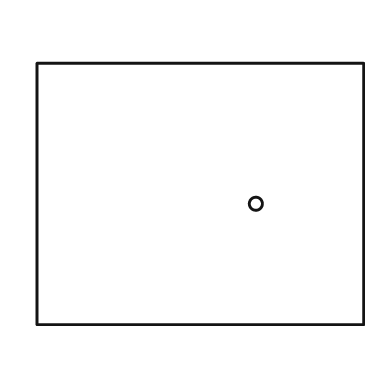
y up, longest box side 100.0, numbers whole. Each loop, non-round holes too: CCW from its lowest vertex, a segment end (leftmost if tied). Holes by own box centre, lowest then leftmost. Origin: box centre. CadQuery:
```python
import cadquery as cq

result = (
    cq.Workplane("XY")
    .moveTo(-50.0, -40.0)
    .lineTo(50.0, -40.0)
    .lineTo(50.0, 40.0)
    .lineTo(-50.0, 40.0)
    .close()
    .moveTo(17.0, -3.0)
    .circle(2.0)
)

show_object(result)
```